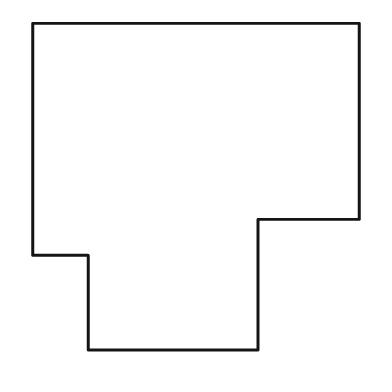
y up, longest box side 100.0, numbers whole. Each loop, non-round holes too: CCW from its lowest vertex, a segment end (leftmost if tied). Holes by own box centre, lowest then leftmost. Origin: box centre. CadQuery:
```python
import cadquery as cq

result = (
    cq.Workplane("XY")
    .moveTo(-33.0, -50.0)
    .lineTo(19.0, -50.0)
    .lineTo(19.0, -10.0)
    .lineTo(50.0, -10.0)
    .lineTo(50.0, 50.0)
    .lineTo(-50.0, 50.0)
    .lineTo(-50.0, -21.0)
    .lineTo(-33.0, -21.0)
    .close()
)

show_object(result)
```